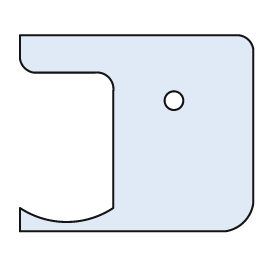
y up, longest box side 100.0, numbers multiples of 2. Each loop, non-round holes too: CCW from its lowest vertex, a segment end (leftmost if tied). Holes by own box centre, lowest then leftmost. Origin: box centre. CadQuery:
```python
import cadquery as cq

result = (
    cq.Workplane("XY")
    .moveTo(-50.0, -42.0)
    .lineTo(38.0, -42.0)
    .threePointArc((46.0, -38.0), (50.0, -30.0))
    .lineTo(50.0, 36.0)
    .threePointArc((48.0, 40.0), (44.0, 42.0))
    .lineTo(-50.0, 42.0)
    .lineTo(-50.0, 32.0)
    .threePointArc((-48.0, 28.0), (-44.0, 26.0))
    .lineTo(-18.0, 26.0)
    .threePointArc((-12.0, 24.0), (-10.0, 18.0))
    .lineTo(-10.0, -32.0)
    .threePointArc((-30.0, -38.0), (-50.0, -32.0))
    .close()
    .moveTo(16.0, 14.0)
    .circle(4.0)
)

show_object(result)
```